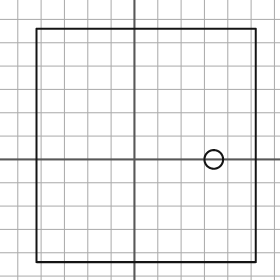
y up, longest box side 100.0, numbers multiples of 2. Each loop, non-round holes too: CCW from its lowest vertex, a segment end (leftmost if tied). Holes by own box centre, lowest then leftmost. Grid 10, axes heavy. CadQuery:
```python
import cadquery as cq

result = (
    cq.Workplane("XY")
    .moveTo(-42.0, -44.0)
    .lineTo(52.0, -44.0)
    .lineTo(52.0, 56.0)
    .lineTo(-42.0, 56.0)
    .close()
    .moveTo(34.0, 0.0)
    .circle(4.0)
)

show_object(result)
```